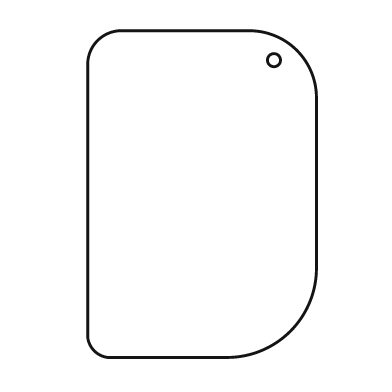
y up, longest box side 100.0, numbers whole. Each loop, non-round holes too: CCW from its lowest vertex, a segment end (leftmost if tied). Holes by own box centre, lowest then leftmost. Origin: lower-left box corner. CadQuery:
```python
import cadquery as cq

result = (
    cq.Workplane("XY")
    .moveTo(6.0, 0.0)
    .lineTo(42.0, 0.0)
    .threePointArc((62.0, 8.0), (70.0, 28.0))
    .lineTo(70.0, 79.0)
    .threePointArc((64.0, 94.0), (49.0, 100.0))
    .lineTo(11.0, 100.0)
    .threePointArc((3.0, 97.0), (0.0, 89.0))
    .lineTo(0.0, 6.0)
    .threePointArc((2.0, 2.0), (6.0, 0.0))
    .close()
    .moveTo(57.0, 91.0)
    .circle(2.0)
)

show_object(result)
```